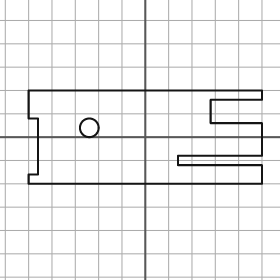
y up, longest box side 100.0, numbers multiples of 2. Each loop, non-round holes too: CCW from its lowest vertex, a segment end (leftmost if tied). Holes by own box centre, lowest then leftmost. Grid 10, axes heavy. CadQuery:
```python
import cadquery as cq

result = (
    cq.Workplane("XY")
    .moveTo(-50.0, -20.0)
    .lineTo(50.0, -20.0)
    .lineTo(50.0, -12.0)
    .lineTo(14.0, -12.0)
    .lineTo(14.0, -8.0)
    .lineTo(50.0, -8.0)
    .lineTo(50.0, 6.0)
    .lineTo(28.0, 6.0)
    .lineTo(28.0, 16.0)
    .lineTo(50.0, 16.0)
    .lineTo(50.0, 20.0)
    .lineTo(-50.0, 20.0)
    .lineTo(-50.0, 8.0)
    .lineTo(-46.0, 8.0)
    .lineTo(-46.0, -16.0)
    .lineTo(-50.0, -16.0)
    .close()
    .moveTo(-24.0, 4.0)
    .circle(4.0)
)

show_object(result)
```